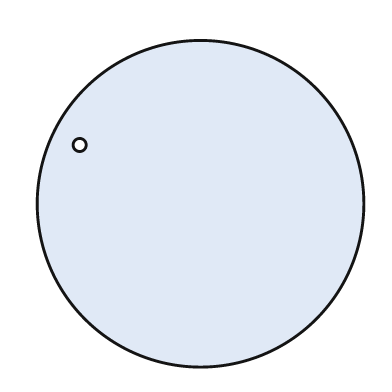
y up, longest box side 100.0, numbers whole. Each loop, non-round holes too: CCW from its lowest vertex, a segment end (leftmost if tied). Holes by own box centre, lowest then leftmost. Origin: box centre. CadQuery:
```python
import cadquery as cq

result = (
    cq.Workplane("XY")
    .moveTo(0.0, 0.0)
    .circle(50.0)
    .moveTo(-37.0, 18.0)
    .circle(2.0)
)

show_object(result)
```